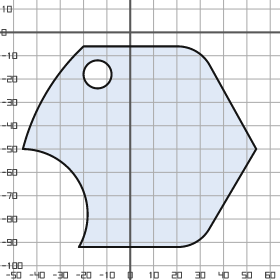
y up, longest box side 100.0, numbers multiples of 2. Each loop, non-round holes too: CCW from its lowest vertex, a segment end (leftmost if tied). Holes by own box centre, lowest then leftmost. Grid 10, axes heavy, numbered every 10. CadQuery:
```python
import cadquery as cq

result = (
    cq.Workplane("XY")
    .moveTo(-22.0, -92.0)
    .lineTo(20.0, -92.0)
    .threePointArc((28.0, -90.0), (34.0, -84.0))
    .lineTo(54.0, -50.0)
    .lineTo(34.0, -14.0)
    .threePointArc((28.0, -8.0), (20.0, -6.0))
    .lineTo(-20.0, -6.0)
    .threePointArc((-36.0, -26.0), (-46.0, -50.0))
    .threePointArc((-22.0, -64.0), (-22.0, -92.0))
    .close()
    .moveTo(-14.0, -18.0)
    .circle(6.0)
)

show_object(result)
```